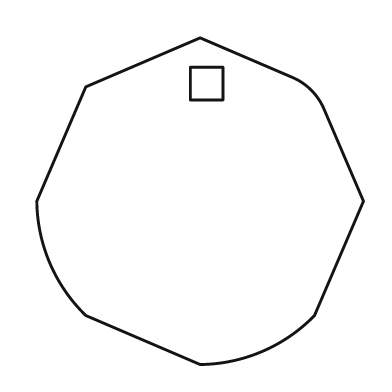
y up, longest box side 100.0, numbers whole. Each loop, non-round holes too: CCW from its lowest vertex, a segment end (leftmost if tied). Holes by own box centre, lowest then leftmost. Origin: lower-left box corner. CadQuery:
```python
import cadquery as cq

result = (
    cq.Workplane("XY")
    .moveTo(50.0, 0.0)
    .threePointArc((69.0, 4.0), (85.0, 15.0))
    .lineTo(100.0, 50.0)
    .lineTo(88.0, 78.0)
    .threePointArc((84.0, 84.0), (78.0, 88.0))
    .lineTo(50.0, 100.0)
    .lineTo(15.0, 85.0)
    .lineTo(0.0, 50.0)
    .threePointArc((4.0, 31.0), (15.0, 15.0))
    .close()
    .moveTo(47.0, 81.0)
    .lineTo(57.0, 81.0)
    .lineTo(57.0, 91.0)
    .lineTo(47.0, 91.0)
    .close()
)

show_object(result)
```